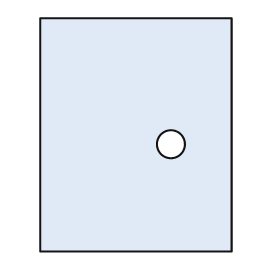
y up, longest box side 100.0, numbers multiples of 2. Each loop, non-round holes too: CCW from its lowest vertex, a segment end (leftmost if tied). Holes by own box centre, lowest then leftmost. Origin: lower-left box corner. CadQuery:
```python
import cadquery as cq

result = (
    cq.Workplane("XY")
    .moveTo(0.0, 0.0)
    .lineTo(82.0, 0.0)
    .lineTo(82.0, 100.0)
    .lineTo(0.0, 100.0)
    .close()
    .moveTo(56.0, 46.0)
    .circle(6.0)
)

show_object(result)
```